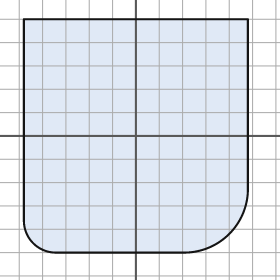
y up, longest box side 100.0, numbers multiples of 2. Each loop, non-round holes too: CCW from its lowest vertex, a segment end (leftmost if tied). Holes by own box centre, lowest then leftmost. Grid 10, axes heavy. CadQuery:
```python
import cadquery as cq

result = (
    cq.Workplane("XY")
    .moveTo(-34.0, -50.0)
    .lineTo(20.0, -50.0)
    .threePointArc((40.0, -42.0), (48.0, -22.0))
    .lineTo(48.0, 50.0)
    .lineTo(-48.0, 50.0)
    .lineTo(-48.0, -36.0)
    .threePointArc((-44.0, -46.0), (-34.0, -50.0))
    .close()
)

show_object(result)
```